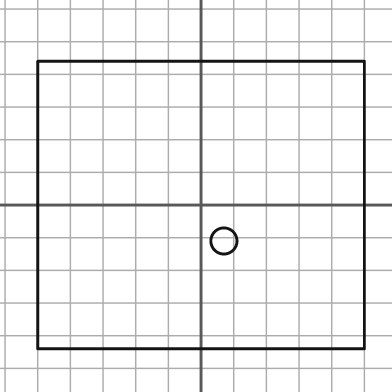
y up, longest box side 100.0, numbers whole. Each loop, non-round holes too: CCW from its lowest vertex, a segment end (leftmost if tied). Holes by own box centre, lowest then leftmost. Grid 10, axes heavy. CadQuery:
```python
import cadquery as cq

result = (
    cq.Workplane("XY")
    .moveTo(-50.0, -44.0)
    .lineTo(50.0, -44.0)
    .lineTo(50.0, 44.0)
    .lineTo(-50.0, 44.0)
    .close()
    .moveTo(7.0, -11.0)
    .circle(4.0)
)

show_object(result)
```